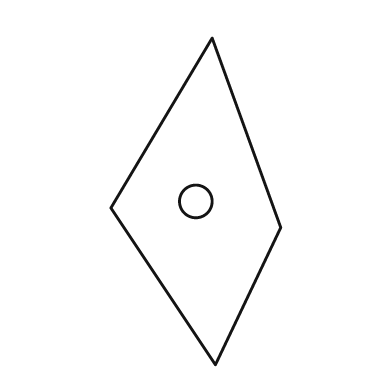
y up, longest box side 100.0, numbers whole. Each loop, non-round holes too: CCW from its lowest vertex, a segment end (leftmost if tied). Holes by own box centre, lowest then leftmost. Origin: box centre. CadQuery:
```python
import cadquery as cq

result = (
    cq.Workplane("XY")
    .moveTo(6.0, -50.0)
    .lineTo(26.0, -8.0)
    .lineTo(5.0, 50.0)
    .lineTo(-26.0, -2.0)
    .close()
    .moveTo(0.0, 0.0)
    .circle(5.0)
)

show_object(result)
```